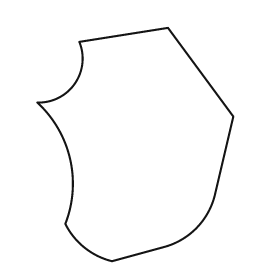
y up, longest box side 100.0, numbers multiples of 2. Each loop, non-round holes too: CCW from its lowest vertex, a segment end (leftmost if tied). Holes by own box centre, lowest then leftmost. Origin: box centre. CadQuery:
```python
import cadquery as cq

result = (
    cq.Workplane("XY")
    .moveTo(-10.0, -50.0)
    .lineTo(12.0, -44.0)
    .threePointArc((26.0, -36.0), (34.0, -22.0))
    .lineTo(42.0, 12.0)
    .lineTo(14.0, 50.0)
    .lineTo(-24.0, 44.0)
    .threePointArc((-26.0, 26.0), (-42.0, 18.0))
    .threePointArc((-28.0, -6.0), (-30.0, -34.0))
    .threePointArc((-22.0, -44.0), (-10.0, -50.0))
    .close()
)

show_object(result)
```